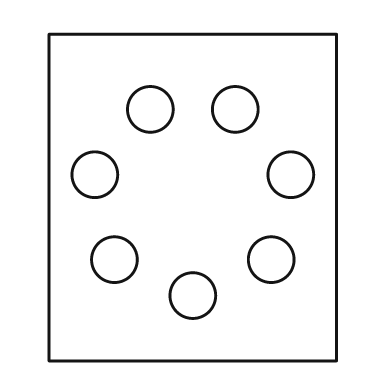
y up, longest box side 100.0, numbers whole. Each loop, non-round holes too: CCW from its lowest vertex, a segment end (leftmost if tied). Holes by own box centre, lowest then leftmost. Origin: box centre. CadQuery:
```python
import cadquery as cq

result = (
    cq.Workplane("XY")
    .moveTo(-44.0, -50.0)
    .lineTo(44.0, -50.0)
    .lineTo(44.0, 50.0)
    .lineTo(-44.0, 50.0)
    .close()
    .moveTo(0.0, -30.0)
    .circle(7.0)
    .moveTo(-24.0, -19.0)
    .circle(7.0)
    .moveTo(24.0, -19.0)
    .circle(7.0)
    .moveTo(-30.0, 7.0)
    .circle(7.0)
    .moveTo(30.0, 7.0)
    .circle(7.0)
    .moveTo(-13.0, 27.0)
    .circle(7.0)
    .moveTo(13.0, 27.0)
    .circle(7.0)
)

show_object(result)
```